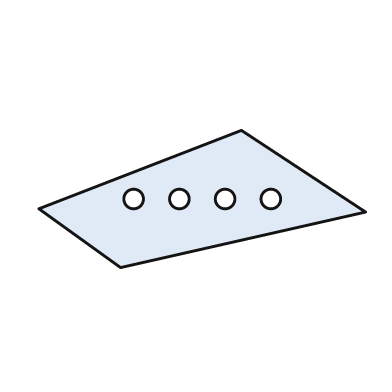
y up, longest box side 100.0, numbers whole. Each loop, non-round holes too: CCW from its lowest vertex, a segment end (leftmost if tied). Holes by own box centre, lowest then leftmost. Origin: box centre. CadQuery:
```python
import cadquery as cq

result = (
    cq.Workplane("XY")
    .moveTo(-25.0, -21.0)
    .lineTo(50.0, -4.0)
    .lineTo(12.0, 21.0)
    .lineTo(-50.0, -3.0)
    .close()
    .moveTo(-21.0, 0.0)
    .circle(3.0)
    .moveTo(-7.0, 0.0)
    .circle(3.0)
    .moveTo(7.0, 0.0)
    .circle(3.0)
    .moveTo(21.0, 0.0)
    .circle(3.0)
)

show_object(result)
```